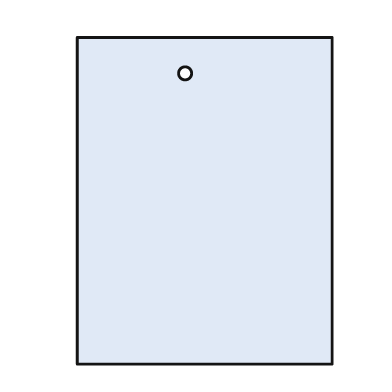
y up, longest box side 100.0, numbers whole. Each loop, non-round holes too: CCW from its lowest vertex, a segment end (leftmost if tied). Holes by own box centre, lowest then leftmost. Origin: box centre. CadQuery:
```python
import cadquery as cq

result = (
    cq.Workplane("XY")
    .moveTo(-39.0, -50.0)
    .lineTo(39.0, -50.0)
    .lineTo(39.0, 50.0)
    .lineTo(-39.0, 50.0)
    .close()
    .moveTo(-6.0, 39.0)
    .circle(2.0)
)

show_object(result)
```